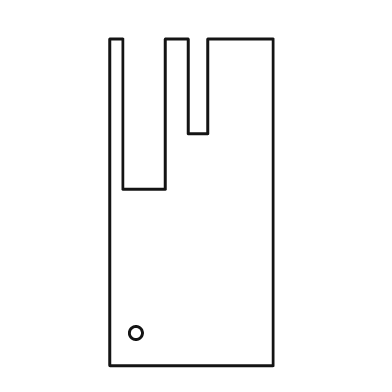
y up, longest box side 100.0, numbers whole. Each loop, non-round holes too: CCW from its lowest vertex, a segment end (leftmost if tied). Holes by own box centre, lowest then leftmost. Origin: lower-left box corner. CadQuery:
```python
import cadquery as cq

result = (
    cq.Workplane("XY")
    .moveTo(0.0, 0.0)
    .lineTo(50.0, 0.0)
    .lineTo(50.0, 100.0)
    .lineTo(30.0, 100.0)
    .lineTo(30.0, 71.0)
    .lineTo(24.0, 71.0)
    .lineTo(24.0, 100.0)
    .lineTo(17.0, 100.0)
    .lineTo(17.0, 54.0)
    .lineTo(4.0, 54.0)
    .lineTo(4.0, 100.0)
    .lineTo(0.0, 100.0)
    .close()
    .moveTo(8.0, 10.0)
    .circle(2.0)
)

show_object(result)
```